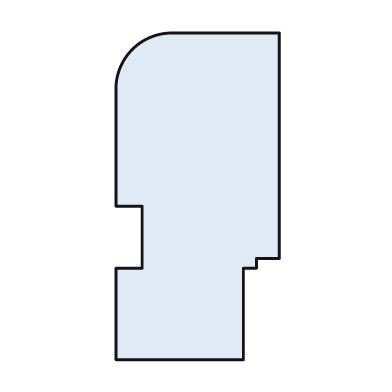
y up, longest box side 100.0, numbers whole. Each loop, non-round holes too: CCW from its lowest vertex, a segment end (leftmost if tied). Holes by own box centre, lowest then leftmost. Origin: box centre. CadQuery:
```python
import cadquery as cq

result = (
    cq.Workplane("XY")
    .moveTo(-25.0, -50.0)
    .lineTo(14.0, -50.0)
    .lineTo(14.0, -22.0)
    .lineTo(18.0, -22.0)
    .lineTo(18.0, -19.0)
    .lineTo(25.0, -19.0)
    .lineTo(25.0, 50.0)
    .lineTo(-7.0, 50.0)
    .threePointArc((-20.0, 45.0), (-25.0, 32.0))
    .lineTo(-25.0, -3.0)
    .lineTo(-17.0, -3.0)
    .lineTo(-17.0, -22.0)
    .lineTo(-25.0, -22.0)
    .close()
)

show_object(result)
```